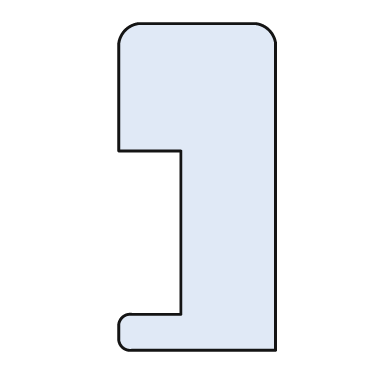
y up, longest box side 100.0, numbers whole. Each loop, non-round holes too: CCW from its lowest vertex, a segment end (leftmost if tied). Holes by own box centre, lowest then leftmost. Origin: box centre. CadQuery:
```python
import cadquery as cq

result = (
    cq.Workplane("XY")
    .moveTo(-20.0, -50.0)
    .lineTo(24.0, -50.0)
    .lineTo(24.0, 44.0)
    .threePointArc((22.0, 48.0), (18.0, 50.0))
    .lineTo(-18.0, 50.0)
    .threePointArc((-22.0, 48.0), (-24.0, 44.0))
    .lineTo(-24.0, 11.0)
    .lineTo(-5.0, 11.0)
    .lineTo(-5.0, -39.0)
    .lineTo(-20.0, -39.0)
    .threePointArc((-23.0, -40.0), (-24.0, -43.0))
    .lineTo(-24.0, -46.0)
    .threePointArc((-23.0, -49.0), (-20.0, -50.0))
    .close()
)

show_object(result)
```